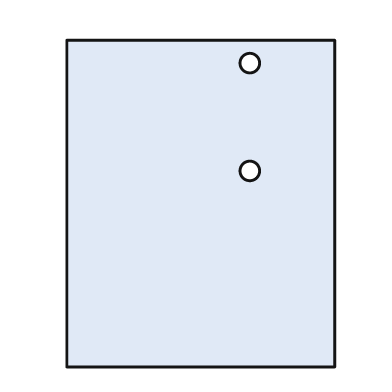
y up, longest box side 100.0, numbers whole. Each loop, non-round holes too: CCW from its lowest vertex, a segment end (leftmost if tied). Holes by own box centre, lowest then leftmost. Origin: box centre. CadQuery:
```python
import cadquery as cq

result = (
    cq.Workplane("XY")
    .moveTo(-41.0, -50.0)
    .lineTo(41.0, -50.0)
    .lineTo(41.0, 50.0)
    .lineTo(-41.0, 50.0)
    .close()
    .moveTo(15.0, 10.0)
    .circle(3.0)
    .moveTo(15.0, 43.0)
    .circle(3.0)
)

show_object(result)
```